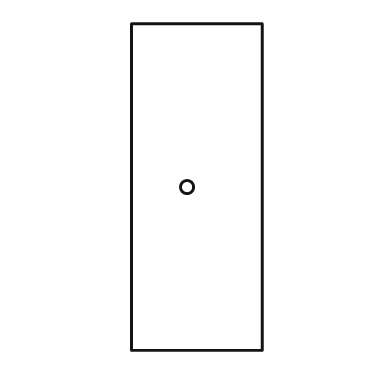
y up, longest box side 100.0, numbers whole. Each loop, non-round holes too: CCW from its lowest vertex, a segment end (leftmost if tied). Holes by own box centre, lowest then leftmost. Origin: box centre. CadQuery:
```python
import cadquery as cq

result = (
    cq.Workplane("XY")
    .moveTo(-20.0, -50.0)
    .lineTo(20.0, -50.0)
    .lineTo(20.0, 50.0)
    .lineTo(-20.0, 50.0)
    .close()
    .moveTo(-3.0, 0.0)
    .circle(2.0)
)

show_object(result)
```